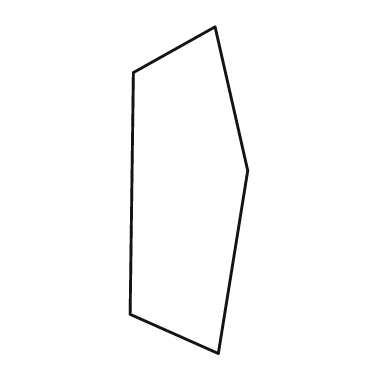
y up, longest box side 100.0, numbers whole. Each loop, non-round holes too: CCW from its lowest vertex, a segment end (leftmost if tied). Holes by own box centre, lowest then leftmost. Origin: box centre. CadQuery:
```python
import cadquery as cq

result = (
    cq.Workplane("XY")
    .moveTo(9.0, -50.0)
    .lineTo(18.0, 6.0)
    .lineTo(8.0, 50.0)
    .lineTo(-17.0, 36.0)
    .lineTo(-18.0, -38.0)
    .close()
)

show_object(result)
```